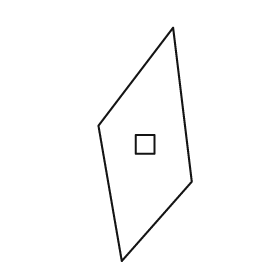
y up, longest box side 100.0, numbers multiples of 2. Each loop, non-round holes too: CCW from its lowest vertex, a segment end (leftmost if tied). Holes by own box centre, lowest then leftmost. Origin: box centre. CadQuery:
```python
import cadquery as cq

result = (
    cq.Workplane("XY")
    .moveTo(-10.0, -50.0)
    .lineTo(20.0, -16.0)
    .lineTo(12.0, 50.0)
    .lineTo(-20.0, 8.0)
    .close()
    .moveTo(-4.0, -4.0)
    .lineTo(4.0, -4.0)
    .lineTo(4.0, 4.0)
    .lineTo(-4.0, 4.0)
    .close()
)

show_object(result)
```